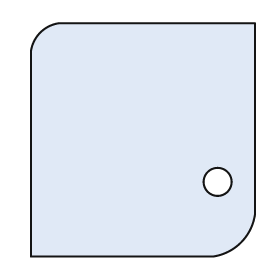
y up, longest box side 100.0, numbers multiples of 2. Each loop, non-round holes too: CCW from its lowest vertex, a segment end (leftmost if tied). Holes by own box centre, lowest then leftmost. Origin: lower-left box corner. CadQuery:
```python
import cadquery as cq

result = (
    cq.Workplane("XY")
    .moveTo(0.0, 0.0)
    .lineTo(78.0, 0.0)
    .threePointArc((90.0, 6.0), (96.0, 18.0))
    .lineTo(96.0, 100.0)
    .lineTo(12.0, 100.0)
    .threePointArc((4.0, 96.0), (0.0, 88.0))
    .close()
    .moveTo(80.0, 32.0)
    .circle(6.0)
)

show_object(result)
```